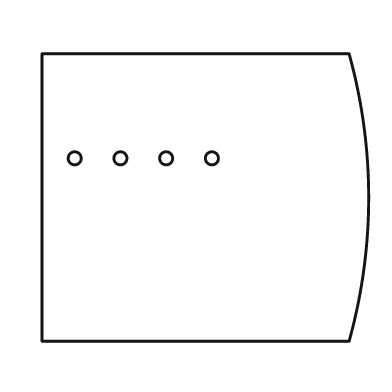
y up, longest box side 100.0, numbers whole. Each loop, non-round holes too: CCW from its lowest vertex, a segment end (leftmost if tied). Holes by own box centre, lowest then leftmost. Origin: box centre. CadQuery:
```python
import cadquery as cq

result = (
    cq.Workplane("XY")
    .moveTo(-50.0, -44.0)
    .lineTo(44.0, -44.0)
    .threePointArc((50.0, 0.0), (44.0, 44.0))
    .lineTo(-50.0, 44.0)
    .close()
    .moveTo(-40.0, 12.0)
    .circle(2.0)
    .moveTo(-26.0, 12.0)
    .circle(2.0)
    .moveTo(-12.0, 12.0)
    .circle(2.0)
    .moveTo(2.0, 12.0)
    .circle(2.0)
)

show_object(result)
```